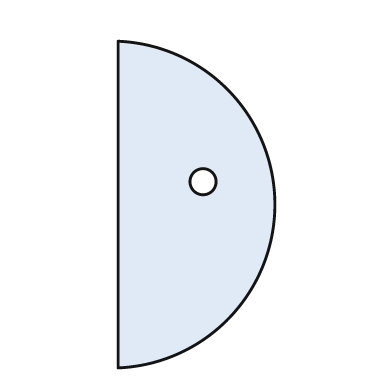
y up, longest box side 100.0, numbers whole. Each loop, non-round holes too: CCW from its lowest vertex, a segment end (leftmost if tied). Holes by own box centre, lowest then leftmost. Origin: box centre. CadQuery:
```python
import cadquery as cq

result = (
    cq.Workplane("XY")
    .moveTo(-24.0, -50.0)
    .threePointArc((24.0, 0.0), (-24.0, 50.0))
    .close()
    .moveTo(2.0, 7.0)
    .circle(4.0)
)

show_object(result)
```